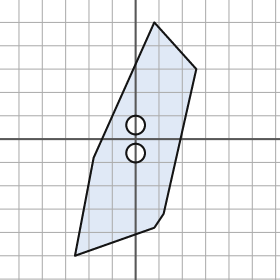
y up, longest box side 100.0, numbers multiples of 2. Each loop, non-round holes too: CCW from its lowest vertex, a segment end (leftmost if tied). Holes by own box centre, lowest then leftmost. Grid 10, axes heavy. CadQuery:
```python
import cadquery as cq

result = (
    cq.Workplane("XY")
    .moveTo(-26.0, -50.0)
    .lineTo(8.0, -38.0)
    .lineTo(12.0, -32.0)
    .lineTo(26.0, 30.0)
    .lineTo(8.0, 50.0)
    .lineTo(-18.0, -8.0)
    .close()
    .moveTo(0.0, -6.0)
    .circle(4.0)
    .moveTo(0.0, 6.0)
    .circle(4.0)
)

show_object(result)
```